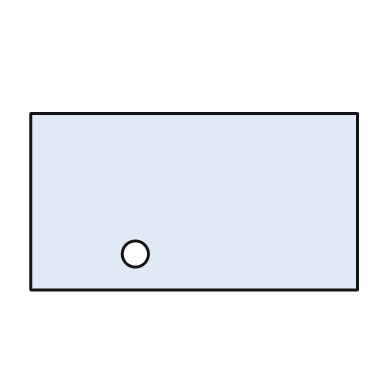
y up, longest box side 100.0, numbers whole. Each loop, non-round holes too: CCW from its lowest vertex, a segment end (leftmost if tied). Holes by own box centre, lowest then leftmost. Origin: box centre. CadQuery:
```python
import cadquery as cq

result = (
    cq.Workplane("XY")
    .moveTo(-50.0, -27.0)
    .lineTo(50.0, -27.0)
    .lineTo(50.0, 27.0)
    .lineTo(-50.0, 27.0)
    .close()
    .moveTo(-18.0, -16.0)
    .circle(4.0)
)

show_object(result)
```